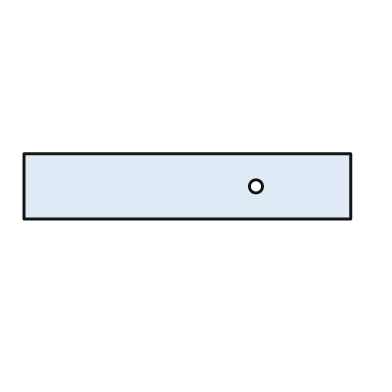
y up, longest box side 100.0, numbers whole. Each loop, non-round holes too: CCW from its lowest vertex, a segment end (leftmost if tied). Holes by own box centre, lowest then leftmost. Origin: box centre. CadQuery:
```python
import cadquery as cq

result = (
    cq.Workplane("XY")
    .moveTo(-50.0, -10.0)
    .lineTo(50.0, -10.0)
    .lineTo(50.0, 10.0)
    .lineTo(-50.0, 10.0)
    .close()
    .moveTo(21.0, 0.0)
    .circle(2.0)
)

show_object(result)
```